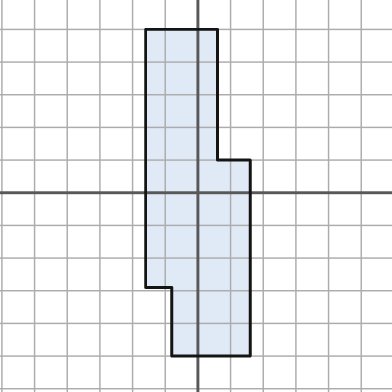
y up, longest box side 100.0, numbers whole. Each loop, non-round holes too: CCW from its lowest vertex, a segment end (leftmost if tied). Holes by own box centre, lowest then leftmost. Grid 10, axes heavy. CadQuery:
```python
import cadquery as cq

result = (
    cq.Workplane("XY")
    .moveTo(-8.0, -50.0)
    .lineTo(16.0, -50.0)
    .lineTo(16.0, 10.0)
    .lineTo(6.0, 10.0)
    .lineTo(6.0, 50.0)
    .lineTo(-16.0, 50.0)
    .lineTo(-16.0, -29.0)
    .lineTo(-8.0, -29.0)
    .close()
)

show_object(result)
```